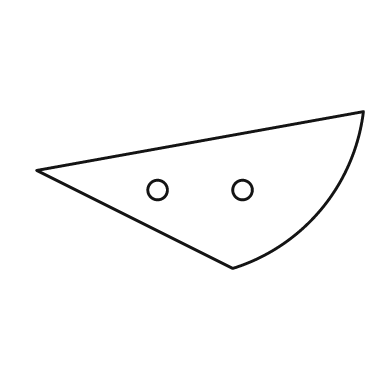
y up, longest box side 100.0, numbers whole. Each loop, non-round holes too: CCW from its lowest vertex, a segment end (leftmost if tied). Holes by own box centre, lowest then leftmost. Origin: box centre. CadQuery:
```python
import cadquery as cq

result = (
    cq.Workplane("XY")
    .moveTo(10.0, -24.0)
    .threePointArc((37.0, -6.0), (50.0, 24.0))
    .lineTo(-50.0, 6.0)
    .close()
    .moveTo(-13.0, 0.0)
    .circle(3.0)
    .moveTo(13.0, 0.0)
    .circle(3.0)
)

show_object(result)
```